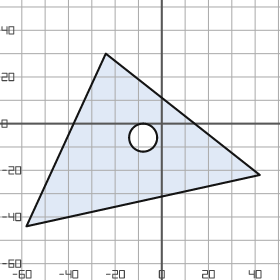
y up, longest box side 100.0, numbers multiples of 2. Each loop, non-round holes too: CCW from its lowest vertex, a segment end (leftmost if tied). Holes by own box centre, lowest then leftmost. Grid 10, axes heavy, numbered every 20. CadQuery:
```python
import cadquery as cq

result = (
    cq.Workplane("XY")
    .moveTo(-58.0, -44.0)
    .lineTo(42.0, -22.0)
    .lineTo(-24.0, 30.0)
    .close()
    .moveTo(-8.0, -6.0)
    .circle(6.0)
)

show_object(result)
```